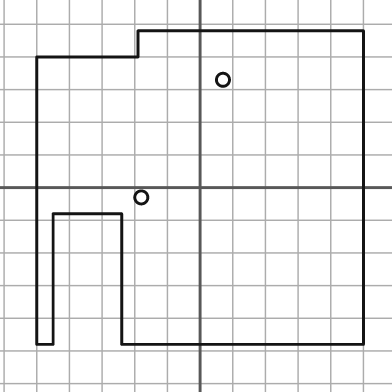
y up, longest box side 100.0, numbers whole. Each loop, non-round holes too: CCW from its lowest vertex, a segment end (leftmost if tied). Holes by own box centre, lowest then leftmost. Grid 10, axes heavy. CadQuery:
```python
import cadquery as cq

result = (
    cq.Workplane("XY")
    .moveTo(-50.0, -48.0)
    .lineTo(-45.0, -48.0)
    .lineTo(-45.0, -8.0)
    .lineTo(-24.0, -8.0)
    .lineTo(-24.0, -48.0)
    .lineTo(50.0, -48.0)
    .lineTo(50.0, 48.0)
    .lineTo(-19.0, 48.0)
    .lineTo(-19.0, 40.0)
    .lineTo(-50.0, 40.0)
    .close()
    .moveTo(-18.0, -3.0)
    .circle(2.0)
    .moveTo(7.0, 33.0)
    .circle(2.0)
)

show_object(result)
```